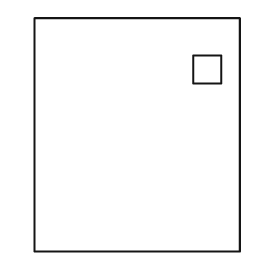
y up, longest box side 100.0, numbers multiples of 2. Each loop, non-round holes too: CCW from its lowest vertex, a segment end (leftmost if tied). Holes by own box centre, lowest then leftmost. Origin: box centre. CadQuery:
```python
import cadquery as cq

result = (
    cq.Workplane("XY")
    .moveTo(-44.0, -50.0)
    .lineTo(44.0, -50.0)
    .lineTo(44.0, 50.0)
    .lineTo(-44.0, 50.0)
    .close()
    .moveTo(24.0, 22.0)
    .lineTo(36.0, 22.0)
    .lineTo(36.0, 34.0)
    .lineTo(24.0, 34.0)
    .close()
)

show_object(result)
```